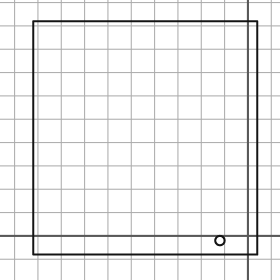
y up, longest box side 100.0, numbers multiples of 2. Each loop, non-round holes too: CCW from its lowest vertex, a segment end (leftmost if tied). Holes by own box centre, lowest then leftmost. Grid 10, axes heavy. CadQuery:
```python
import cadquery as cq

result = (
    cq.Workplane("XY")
    .moveTo(-92.0, -8.0)
    .lineTo(4.0, -8.0)
    .lineTo(4.0, 92.0)
    .lineTo(-92.0, 92.0)
    .close()
    .moveTo(-12.0, -2.0)
    .circle(2.0)
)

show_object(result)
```